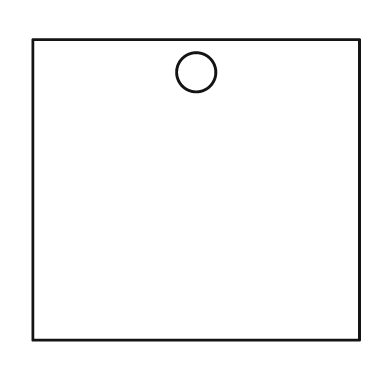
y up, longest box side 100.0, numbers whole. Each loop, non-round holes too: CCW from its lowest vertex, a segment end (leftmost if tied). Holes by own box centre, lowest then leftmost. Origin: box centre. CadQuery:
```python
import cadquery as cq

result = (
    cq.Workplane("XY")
    .moveTo(-50.0, -46.0)
    .lineTo(50.0, -46.0)
    .lineTo(50.0, 46.0)
    .lineTo(-50.0, 46.0)
    .close()
    .moveTo(0.0, 36.0)
    .circle(6.0)
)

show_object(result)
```